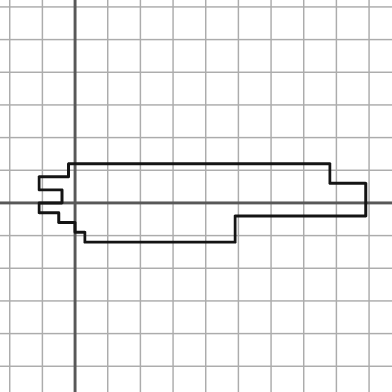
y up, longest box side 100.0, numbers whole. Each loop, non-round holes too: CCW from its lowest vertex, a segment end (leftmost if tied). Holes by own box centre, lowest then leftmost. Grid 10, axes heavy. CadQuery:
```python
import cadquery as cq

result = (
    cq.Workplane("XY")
    .moveTo(3.0, -12.0)
    .lineTo(49.0, -12.0)
    .lineTo(49.0, -4.0)
    .lineTo(89.0, -4.0)
    .lineTo(89.0, 6.0)
    .lineTo(78.0, 6.0)
    .lineTo(78.0, 12.0)
    .lineTo(-2.0, 12.0)
    .lineTo(-2.0, 8.0)
    .lineTo(-11.0, 8.0)
    .lineTo(-11.0, 4.0)
    .lineTo(-4.0, 4.0)
    .lineTo(-4.0, 0.0)
    .lineTo(-11.0, 0.0)
    .lineTo(-11.0, -3.0)
    .lineTo(-5.0, -3.0)
    .lineTo(-5.0, -6.0)
    .lineTo(0.0, -6.0)
    .lineTo(0.0, -9.0)
    .lineTo(3.0, -9.0)
    .close()
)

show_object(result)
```